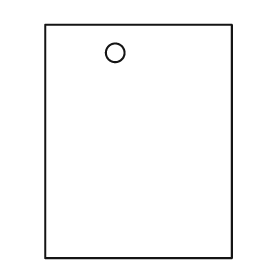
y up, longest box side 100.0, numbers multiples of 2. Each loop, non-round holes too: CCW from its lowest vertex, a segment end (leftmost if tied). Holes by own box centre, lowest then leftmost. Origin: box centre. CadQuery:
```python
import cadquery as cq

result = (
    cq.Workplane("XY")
    .moveTo(-40.0, -50.0)
    .lineTo(40.0, -50.0)
    .lineTo(40.0, 50.0)
    .lineTo(-40.0, 50.0)
    .close()
    .moveTo(-10.0, 38.0)
    .circle(4.0)
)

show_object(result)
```